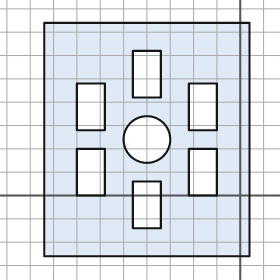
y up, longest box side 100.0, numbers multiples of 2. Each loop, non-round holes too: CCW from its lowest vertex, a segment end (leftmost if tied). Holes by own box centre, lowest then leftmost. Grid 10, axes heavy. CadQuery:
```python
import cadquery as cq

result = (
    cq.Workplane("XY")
    .moveTo(-84.0, -26.0)
    .lineTo(4.0, -26.0)
    .lineTo(4.0, 74.0)
    .lineTo(-84.0, 74.0)
    .close()
    .moveTo(-46.0, -14.0)
    .lineTo(-34.0, -14.0)
    .lineTo(-34.0, 6.0)
    .lineTo(-46.0, 6.0)
    .close()
    .moveTo(-70.0, 0.0)
    .lineTo(-58.0, 0.0)
    .lineTo(-58.0, 20.0)
    .lineTo(-70.0, 20.0)
    .close()
    .moveTo(-22.0, 0.0)
    .lineTo(-10.0, 0.0)
    .lineTo(-10.0, 20.0)
    .lineTo(-22.0, 20.0)
    .close()
    .moveTo(-40.0, 24.0)
    .circle(10.0)
    .moveTo(-70.0, 28.0)
    .lineTo(-58.0, 28.0)
    .lineTo(-58.0, 48.0)
    .lineTo(-70.0, 48.0)
    .close()
    .moveTo(-22.0, 28.0)
    .lineTo(-10.0, 28.0)
    .lineTo(-10.0, 48.0)
    .lineTo(-22.0, 48.0)
    .close()
    .moveTo(-46.0, 42.0)
    .lineTo(-34.0, 42.0)
    .lineTo(-34.0, 62.0)
    .lineTo(-46.0, 62.0)
    .close()
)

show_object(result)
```